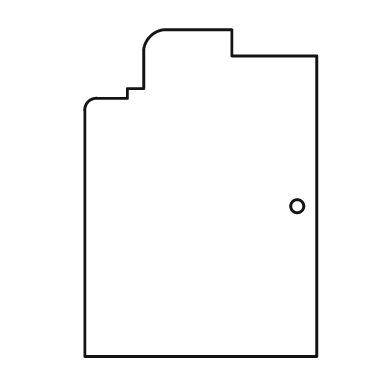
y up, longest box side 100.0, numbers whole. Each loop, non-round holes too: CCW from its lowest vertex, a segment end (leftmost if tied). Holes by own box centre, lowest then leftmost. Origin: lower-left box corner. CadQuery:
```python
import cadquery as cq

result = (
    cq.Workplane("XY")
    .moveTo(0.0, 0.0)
    .lineTo(71.0, 0.0)
    .lineTo(71.0, 92.0)
    .lineTo(45.0, 92.0)
    .lineTo(45.0, 100.0)
    .lineTo(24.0, 100.0)
    .threePointArc((20.0, 98.0), (18.0, 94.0))
    .lineTo(18.0, 82.0)
    .lineTo(13.0, 82.0)
    .lineTo(13.0, 79.0)
    .lineTo(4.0, 79.0)
    .threePointArc((1.0, 78.0), (0.0, 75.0))
    .close()
    .moveTo(65.0, 46.0)
    .circle(2.0)
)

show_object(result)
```